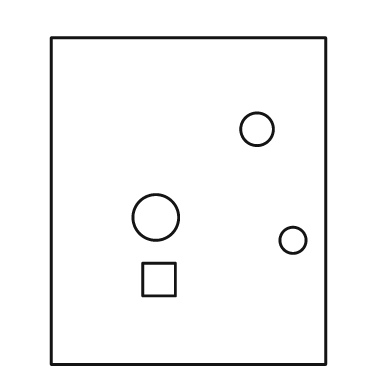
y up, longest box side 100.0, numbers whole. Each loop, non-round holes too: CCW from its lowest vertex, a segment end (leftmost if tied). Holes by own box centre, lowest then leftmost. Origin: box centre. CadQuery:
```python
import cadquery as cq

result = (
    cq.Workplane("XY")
    .moveTo(-42.0, -50.0)
    .lineTo(42.0, -50.0)
    .lineTo(42.0, 50.0)
    .lineTo(-42.0, 50.0)
    .close()
    .moveTo(-14.0, -29.0)
    .lineTo(-4.0, -29.0)
    .lineTo(-4.0, -19.0)
    .lineTo(-14.0, -19.0)
    .close()
    .moveTo(32.0, -12.0)
    .circle(4.0)
    .moveTo(-10.0, -5.0)
    .circle(7.0)
    .moveTo(21.0, 22.0)
    .circle(5.0)
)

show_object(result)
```